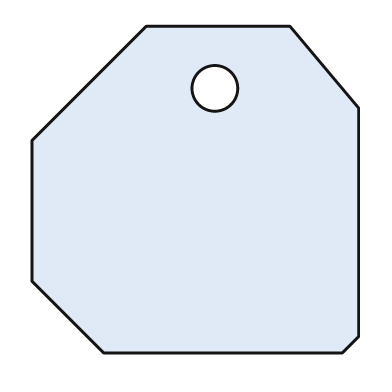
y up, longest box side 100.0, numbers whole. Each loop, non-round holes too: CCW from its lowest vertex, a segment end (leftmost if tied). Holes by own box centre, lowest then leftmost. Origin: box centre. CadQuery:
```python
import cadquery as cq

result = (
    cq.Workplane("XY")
    .moveTo(-28.0, -50.0)
    .lineTo(45.0, -50.0)
    .lineTo(50.0, -45.0)
    .lineTo(50.0, 25.0)
    .lineTo(29.0, 50.0)
    .lineTo(-15.0, 50.0)
    .lineTo(-50.0, 15.0)
    .lineTo(-50.0, -28.0)
    .close()
    .moveTo(6.0, 31.0)
    .circle(7.0)
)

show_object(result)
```